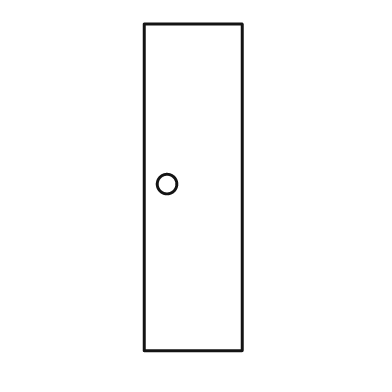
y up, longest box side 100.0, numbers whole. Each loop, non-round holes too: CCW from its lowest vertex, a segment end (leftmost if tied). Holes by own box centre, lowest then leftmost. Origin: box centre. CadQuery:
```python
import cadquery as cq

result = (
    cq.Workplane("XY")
    .moveTo(-15.0, -50.0)
    .lineTo(15.0, -50.0)
    .lineTo(15.0, 50.0)
    .lineTo(-15.0, 50.0)
    .close()
    .moveTo(-8.0, 1.0)
    .circle(3.0)
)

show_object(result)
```